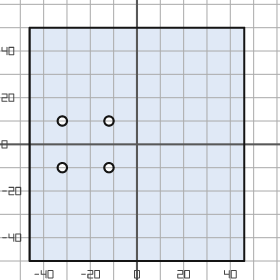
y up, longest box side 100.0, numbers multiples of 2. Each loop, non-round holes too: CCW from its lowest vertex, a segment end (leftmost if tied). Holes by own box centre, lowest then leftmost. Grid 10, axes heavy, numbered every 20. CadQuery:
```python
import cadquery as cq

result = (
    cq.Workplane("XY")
    .moveTo(-46.0, -50.0)
    .lineTo(46.0, -50.0)
    .lineTo(46.0, 50.0)
    .lineTo(-46.0, 50.0)
    .close()
    .moveTo(-32.0, -10.0)
    .circle(2.0)
    .moveTo(-12.0, -10.0)
    .circle(2.0)
    .moveTo(-32.0, 10.0)
    .circle(2.0)
    .moveTo(-12.0, 10.0)
    .circle(2.0)
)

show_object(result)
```